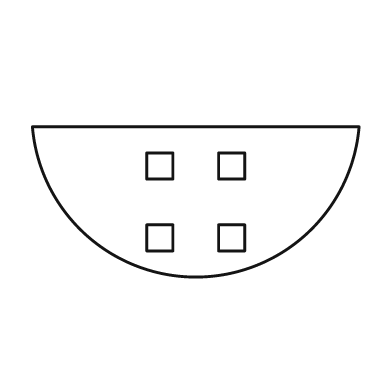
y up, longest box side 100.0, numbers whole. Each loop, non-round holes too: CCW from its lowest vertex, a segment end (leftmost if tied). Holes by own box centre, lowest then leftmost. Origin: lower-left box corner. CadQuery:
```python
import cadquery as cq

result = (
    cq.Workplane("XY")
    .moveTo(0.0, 46.0)
    .threePointArc((50.0, 0.0), (100.0, 46.0))
    .close()
    .moveTo(35.0, 8.0)
    .lineTo(43.0, 8.0)
    .lineTo(43.0, 16.0)
    .lineTo(35.0, 16.0)
    .close()
    .moveTo(57.0, 8.0)
    .lineTo(65.0, 8.0)
    .lineTo(65.0, 16.0)
    .lineTo(57.0, 16.0)
    .close()
    .moveTo(35.0, 30.0)
    .lineTo(43.0, 30.0)
    .lineTo(43.0, 38.0)
    .lineTo(35.0, 38.0)
    .close()
    .moveTo(57.0, 30.0)
    .lineTo(65.0, 30.0)
    .lineTo(65.0, 38.0)
    .lineTo(57.0, 38.0)
    .close()
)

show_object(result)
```